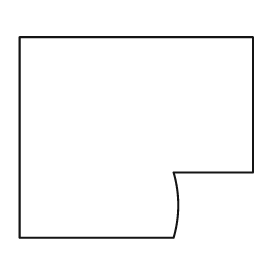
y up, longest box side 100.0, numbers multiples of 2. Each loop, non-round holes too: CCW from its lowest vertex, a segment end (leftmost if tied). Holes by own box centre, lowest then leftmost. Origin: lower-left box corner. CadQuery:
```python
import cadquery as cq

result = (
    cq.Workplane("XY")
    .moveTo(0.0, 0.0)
    .lineTo(66.0, 0.0)
    .threePointArc((68.0, 14.0), (66.0, 28.0))
    .lineTo(100.0, 28.0)
    .lineTo(100.0, 86.0)
    .lineTo(0.0, 86.0)
    .close()
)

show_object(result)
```